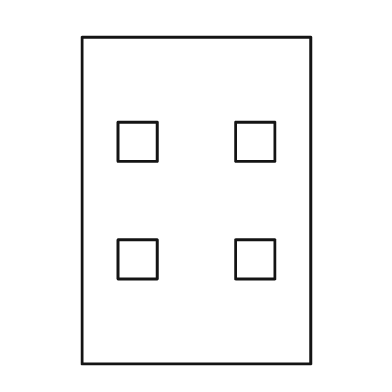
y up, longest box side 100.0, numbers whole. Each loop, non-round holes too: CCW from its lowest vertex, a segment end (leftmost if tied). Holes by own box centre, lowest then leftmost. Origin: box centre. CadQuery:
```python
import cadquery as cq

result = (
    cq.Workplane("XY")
    .moveTo(-35.0, -50.0)
    .lineTo(35.0, -50.0)
    .lineTo(35.0, 50.0)
    .lineTo(-35.0, 50.0)
    .close()
    .moveTo(-24.0, -24.0)
    .lineTo(-12.0, -24.0)
    .lineTo(-12.0, -12.0)
    .lineTo(-24.0, -12.0)
    .close()
    .moveTo(12.0, -24.0)
    .lineTo(24.0, -24.0)
    .lineTo(24.0, -12.0)
    .lineTo(12.0, -12.0)
    .close()
    .moveTo(-24.0, 12.0)
    .lineTo(-12.0, 12.0)
    .lineTo(-12.0, 24.0)
    .lineTo(-24.0, 24.0)
    .close()
    .moveTo(12.0, 12.0)
    .lineTo(24.0, 12.0)
    .lineTo(24.0, 24.0)
    .lineTo(12.0, 24.0)
    .close()
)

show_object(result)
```